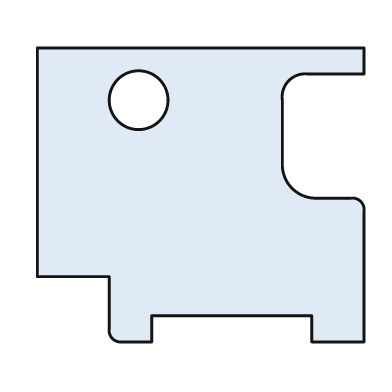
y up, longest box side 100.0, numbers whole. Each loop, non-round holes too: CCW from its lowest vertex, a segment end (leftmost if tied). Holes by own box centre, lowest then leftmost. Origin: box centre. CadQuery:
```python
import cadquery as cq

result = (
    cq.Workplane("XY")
    .moveTo(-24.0, -45.0)
    .lineTo(-15.0, -45.0)
    .lineTo(-15.0, -37.0)
    .lineTo(34.0, -37.0)
    .lineTo(34.0, -45.0)
    .lineTo(50.0, -45.0)
    .lineTo(50.0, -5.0)
    .threePointArc((49.0, -2.0), (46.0, -1.0))
    .lineTo(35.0, -1.0)
    .threePointArc((28.0, 2.0), (25.0, 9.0))
    .lineTo(25.0, 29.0)
    .threePointArc((27.0, 35.0), (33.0, 37.0))
    .lineTo(50.0, 37.0)
    .lineTo(50.0, 45.0)
    .lineTo(-50.0, 45.0)
    .lineTo(-50.0, -25.0)
    .lineTo(-28.0, -25.0)
    .lineTo(-28.0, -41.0)
    .threePointArc((-27.0, -44.0), (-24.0, -45.0))
    .close()
    .moveTo(-19.0, 29.0)
    .circle(9.0)
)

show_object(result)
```